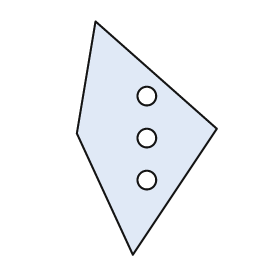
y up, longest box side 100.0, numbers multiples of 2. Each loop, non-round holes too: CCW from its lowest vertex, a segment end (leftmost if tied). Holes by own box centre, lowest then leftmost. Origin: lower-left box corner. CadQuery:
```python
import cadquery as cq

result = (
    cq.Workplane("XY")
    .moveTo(24.0, 0.0)
    .lineTo(60.0, 54.0)
    .lineTo(8.0, 100.0)
    .lineTo(0.0, 52.0)
    .close()
    .moveTo(30.0, 32.0)
    .circle(4.0)
    .moveTo(30.0, 50.0)
    .circle(4.0)
    .moveTo(30.0, 68.0)
    .circle(4.0)
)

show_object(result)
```